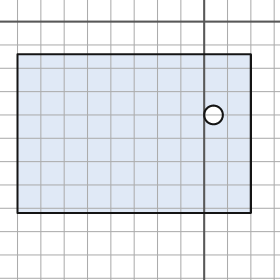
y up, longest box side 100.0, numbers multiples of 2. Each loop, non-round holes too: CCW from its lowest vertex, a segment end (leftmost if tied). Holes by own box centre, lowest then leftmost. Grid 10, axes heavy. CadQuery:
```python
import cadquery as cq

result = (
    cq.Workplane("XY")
    .moveTo(-80.0, -82.0)
    .lineTo(20.0, -82.0)
    .lineTo(20.0, -14.0)
    .lineTo(-80.0, -14.0)
    .close()
    .moveTo(4.0, -40.0)
    .circle(4.0)
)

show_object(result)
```